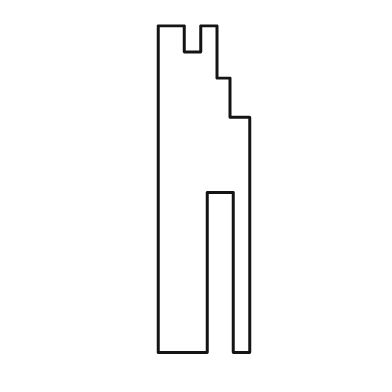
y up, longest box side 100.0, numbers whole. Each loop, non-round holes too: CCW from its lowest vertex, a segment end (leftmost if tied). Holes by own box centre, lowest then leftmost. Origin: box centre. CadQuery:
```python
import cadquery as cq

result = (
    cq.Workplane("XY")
    .moveTo(-14.0, -50.0)
    .lineTo(1.0, -50.0)
    .lineTo(1.0, -1.0)
    .lineTo(9.0, -1.0)
    .lineTo(9.0, -50.0)
    .lineTo(14.0, -50.0)
    .lineTo(14.0, 22.0)
    .lineTo(8.0, 22.0)
    .lineTo(8.0, 34.0)
    .lineTo(4.0, 34.0)
    .lineTo(4.0, 50.0)
    .lineTo(-1.0, 50.0)
    .lineTo(-1.0, 42.0)
    .lineTo(-6.0, 42.0)
    .lineTo(-6.0, 50.0)
    .lineTo(-14.0, 50.0)
    .close()
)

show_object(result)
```